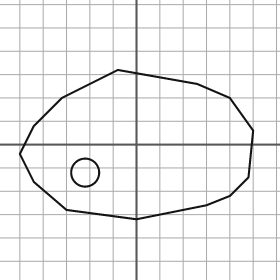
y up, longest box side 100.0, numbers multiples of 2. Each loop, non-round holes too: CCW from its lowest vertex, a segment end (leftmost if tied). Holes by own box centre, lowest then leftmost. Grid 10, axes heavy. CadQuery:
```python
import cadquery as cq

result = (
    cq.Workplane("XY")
    .moveTo(0.0, -32.0)
    .lineTo(30.0, -26.0)
    .lineTo(40.0, -22.0)
    .lineTo(48.0, -14.0)
    .lineTo(50.0, 6.0)
    .lineTo(40.0, 20.0)
    .lineTo(26.0, 26.0)
    .lineTo(-8.0, 32.0)
    .lineTo(-32.0, 20.0)
    .lineTo(-44.0, 8.0)
    .lineTo(-50.0, -4.0)
    .lineTo(-44.0, -16.0)
    .lineTo(-30.0, -28.0)
    .close()
    .moveTo(-22.0, -12.0)
    .circle(6.0)
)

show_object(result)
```